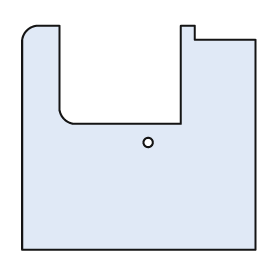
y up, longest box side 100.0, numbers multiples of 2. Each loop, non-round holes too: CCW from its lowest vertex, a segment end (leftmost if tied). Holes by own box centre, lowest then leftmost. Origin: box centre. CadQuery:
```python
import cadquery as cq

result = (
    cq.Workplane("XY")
    .moveTo(-50.0, -48.0)
    .lineTo(50.0, -48.0)
    .lineTo(50.0, 42.0)
    .lineTo(24.0, 42.0)
    .lineTo(24.0, 48.0)
    .lineTo(18.0, 48.0)
    .lineTo(18.0, 6.0)
    .lineTo(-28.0, 6.0)
    .threePointArc((-32.0, 8.0), (-34.0, 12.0))
    .lineTo(-34.0, 48.0)
    .lineTo(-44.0, 48.0)
    .threePointArc((-48.0, 46.0), (-50.0, 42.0))
    .close()
    .moveTo(4.0, -2.0)
    .circle(2.0)
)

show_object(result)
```